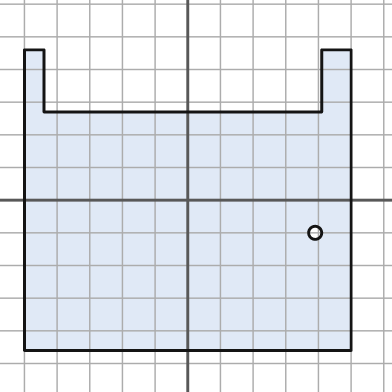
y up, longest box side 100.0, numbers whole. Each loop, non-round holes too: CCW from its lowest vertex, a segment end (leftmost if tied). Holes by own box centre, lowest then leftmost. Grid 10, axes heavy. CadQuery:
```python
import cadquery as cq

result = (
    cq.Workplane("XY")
    .moveTo(-50.0, -46.0)
    .lineTo(50.0, -46.0)
    .lineTo(50.0, 46.0)
    .lineTo(41.0, 46.0)
    .lineTo(41.0, 27.0)
    .lineTo(-44.0, 27.0)
    .lineTo(-44.0, 46.0)
    .lineTo(-50.0, 46.0)
    .close()
    .moveTo(39.0, -10.0)
    .circle(2.0)
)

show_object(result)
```